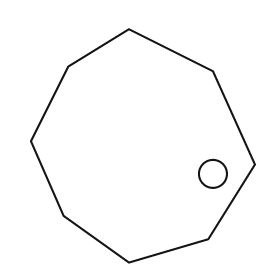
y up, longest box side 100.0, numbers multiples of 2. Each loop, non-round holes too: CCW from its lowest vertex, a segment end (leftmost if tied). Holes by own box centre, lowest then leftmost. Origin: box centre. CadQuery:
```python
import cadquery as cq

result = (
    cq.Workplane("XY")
    .moveTo(-6.0, -50.0)
    .lineTo(28.0, -40.0)
    .lineTo(48.0, -8.0)
    .lineTo(30.0, 32.0)
    .lineTo(-6.0, 50.0)
    .lineTo(-32.0, 34.0)
    .lineTo(-48.0, 2.0)
    .lineTo(-34.0, -30.0)
    .close()
    .moveTo(30.0, -12.0)
    .circle(6.0)
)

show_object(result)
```